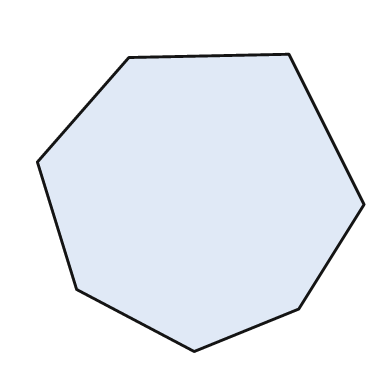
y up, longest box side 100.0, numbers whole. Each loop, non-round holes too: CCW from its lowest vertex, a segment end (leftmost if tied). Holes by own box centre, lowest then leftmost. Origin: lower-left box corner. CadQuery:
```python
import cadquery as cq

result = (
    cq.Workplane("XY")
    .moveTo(48.0, 0.0)
    .lineTo(80.0, 13.0)
    .lineTo(100.0, 45.0)
    .lineTo(77.0, 91.0)
    .lineTo(28.0, 90.0)
    .lineTo(0.0, 58.0)
    .lineTo(12.0, 19.0)
    .close()
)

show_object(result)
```